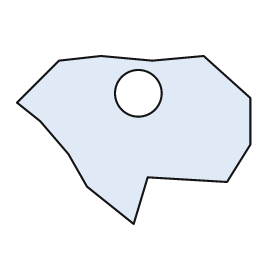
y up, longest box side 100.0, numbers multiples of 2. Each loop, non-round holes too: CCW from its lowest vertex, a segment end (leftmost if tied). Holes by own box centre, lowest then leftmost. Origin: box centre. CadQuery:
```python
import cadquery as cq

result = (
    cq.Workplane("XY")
    .moveTo(0.0, -36.0)
    .lineTo(6.0, -16.0)
    .lineTo(40.0, -18.0)
    .lineTo(50.0, -2.0)
    .lineTo(50.0, 18.0)
    .lineTo(30.0, 36.0)
    .lineTo(8.0, 34.0)
    .lineTo(-14.0, 36.0)
    .lineTo(-32.0, 34.0)
    .lineTo(-50.0, 16.0)
    .lineTo(-40.0, 8.0)
    .lineTo(-28.0, -6.0)
    .lineTo(-20.0, -20.0)
    .close()
    .moveTo(2.0, 20.0)
    .circle(10.0)
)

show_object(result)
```